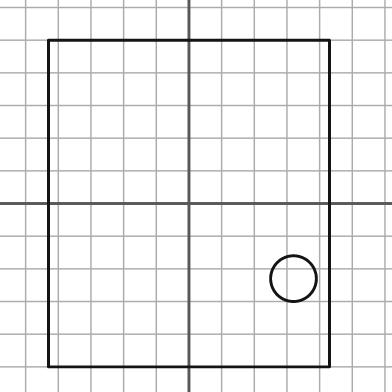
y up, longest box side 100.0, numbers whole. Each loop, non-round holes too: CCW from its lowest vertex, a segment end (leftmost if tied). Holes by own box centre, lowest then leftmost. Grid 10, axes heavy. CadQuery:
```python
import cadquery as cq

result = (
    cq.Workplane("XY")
    .moveTo(-43.0, -50.0)
    .lineTo(43.0, -50.0)
    .lineTo(43.0, 50.0)
    .lineTo(-43.0, 50.0)
    .close()
    .moveTo(32.0, -23.0)
    .circle(7.0)
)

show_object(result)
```